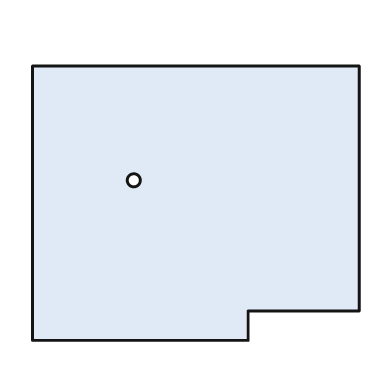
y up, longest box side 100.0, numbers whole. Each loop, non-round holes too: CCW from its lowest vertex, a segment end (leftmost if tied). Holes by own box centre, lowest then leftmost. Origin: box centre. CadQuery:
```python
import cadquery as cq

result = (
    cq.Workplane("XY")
    .moveTo(-50.0, -42.0)
    .lineTo(16.0, -42.0)
    .lineTo(16.0, -33.0)
    .lineTo(50.0, -33.0)
    .lineTo(50.0, 42.0)
    .lineTo(-50.0, 42.0)
    .close()
    .moveTo(-19.0, 7.0)
    .circle(2.0)
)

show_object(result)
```